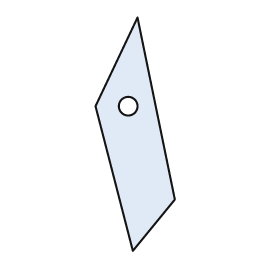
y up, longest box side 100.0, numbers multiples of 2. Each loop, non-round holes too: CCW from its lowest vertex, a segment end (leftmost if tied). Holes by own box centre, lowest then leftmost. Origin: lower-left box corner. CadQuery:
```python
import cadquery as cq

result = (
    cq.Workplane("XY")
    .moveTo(16.0, 0.0)
    .lineTo(34.0, 22.0)
    .lineTo(18.0, 100.0)
    .lineTo(0.0, 62.0)
    .close()
    .moveTo(14.0, 62.0)
    .circle(4.0)
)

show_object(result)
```